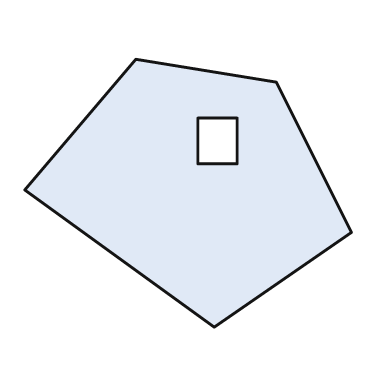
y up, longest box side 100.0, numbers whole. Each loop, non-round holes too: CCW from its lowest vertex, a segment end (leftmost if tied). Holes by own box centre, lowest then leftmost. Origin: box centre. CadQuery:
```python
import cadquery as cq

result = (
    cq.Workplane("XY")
    .moveTo(8.0, -41.0)
    .lineTo(50.0, -12.0)
    .lineTo(27.0, 34.0)
    .lineTo(-16.0, 41.0)
    .lineTo(-50.0, 1.0)
    .close()
    .moveTo(3.0, 9.0)
    .lineTo(15.0, 9.0)
    .lineTo(15.0, 23.0)
    .lineTo(3.0, 23.0)
    .close()
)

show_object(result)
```